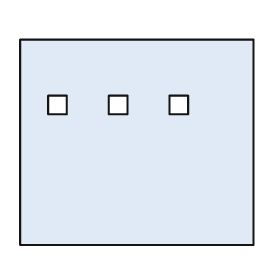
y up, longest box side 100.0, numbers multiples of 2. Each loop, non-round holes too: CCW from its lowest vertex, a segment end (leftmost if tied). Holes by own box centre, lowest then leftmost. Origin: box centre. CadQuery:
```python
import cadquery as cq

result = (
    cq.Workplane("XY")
    .moveTo(-50.0, -44.0)
    .lineTo(50.0, -44.0)
    .lineTo(50.0, 44.0)
    .lineTo(-50.0, 44.0)
    .close()
    .moveTo(-38.0, 12.0)
    .lineTo(-30.0, 12.0)
    .lineTo(-30.0, 20.0)
    .lineTo(-38.0, 20.0)
    .close()
    .moveTo(-12.0, 12.0)
    .lineTo(-4.0, 12.0)
    .lineTo(-4.0, 20.0)
    .lineTo(-12.0, 20.0)
    .close()
    .moveTo(14.0, 12.0)
    .lineTo(22.0, 12.0)
    .lineTo(22.0, 20.0)
    .lineTo(14.0, 20.0)
    .close()
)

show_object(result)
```